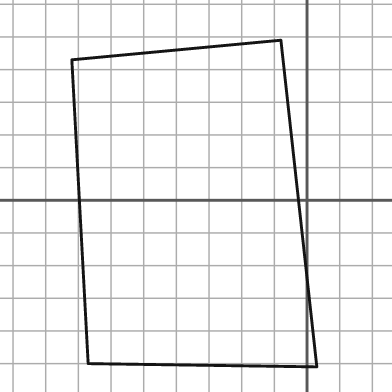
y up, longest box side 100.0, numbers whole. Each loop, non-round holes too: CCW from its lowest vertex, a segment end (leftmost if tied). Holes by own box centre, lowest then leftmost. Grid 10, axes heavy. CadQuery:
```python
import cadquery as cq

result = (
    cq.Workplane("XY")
    .moveTo(3.0, -51.0)
    .lineTo(-8.0, 49.0)
    .lineTo(-72.0, 43.0)
    .lineTo(-67.0, -50.0)
    .close()
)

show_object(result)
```